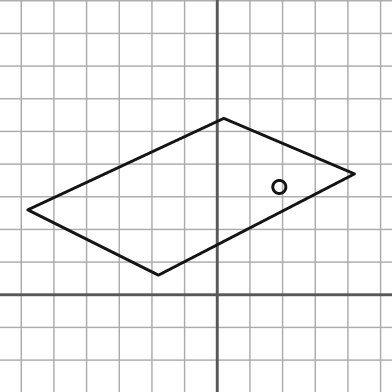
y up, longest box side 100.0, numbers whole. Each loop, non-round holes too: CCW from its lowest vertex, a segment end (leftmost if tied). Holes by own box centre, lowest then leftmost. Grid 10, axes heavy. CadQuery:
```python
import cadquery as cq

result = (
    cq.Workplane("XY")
    .moveTo(-18.0, 6.0)
    .lineTo(42.0, 37.0)
    .lineTo(2.0, 54.0)
    .lineTo(-58.0, 26.0)
    .close()
    .moveTo(19.0, 33.0)
    .circle(2.0)
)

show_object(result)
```